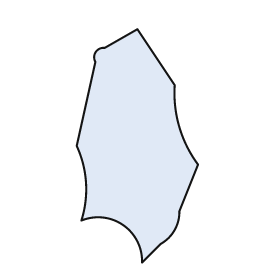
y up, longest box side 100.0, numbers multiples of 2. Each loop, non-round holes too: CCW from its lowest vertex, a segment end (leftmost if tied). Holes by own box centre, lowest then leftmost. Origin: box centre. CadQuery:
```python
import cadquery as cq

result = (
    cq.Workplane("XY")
    .moveTo(2.0, -50.0)
    .lineTo(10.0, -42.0)
    .threePointArc((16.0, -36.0), (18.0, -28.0))
    .lineTo(26.0, -8.0)
    .threePointArc((18.0, 8.0), (16.0, 26.0))
    .lineTo(0.0, 50.0)
    .lineTo(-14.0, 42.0)
    .threePointArc((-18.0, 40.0), (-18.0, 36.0))
    .lineTo(-26.0, 0.0)
    .threePointArc((-22.0, -16.0), (-24.0, -32.0))
    .threePointArc((-6.0, -34.0), (2.0, -50.0))
    .close()
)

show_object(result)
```